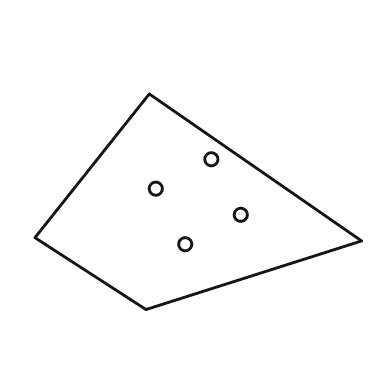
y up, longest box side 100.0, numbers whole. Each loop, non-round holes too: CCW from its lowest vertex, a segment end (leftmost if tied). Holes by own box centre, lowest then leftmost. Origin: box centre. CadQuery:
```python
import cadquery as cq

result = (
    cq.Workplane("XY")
    .moveTo(-16.0, -33.0)
    .lineTo(50.0, -12.0)
    .lineTo(-15.0, 33.0)
    .lineTo(-50.0, -11.0)
    .close()
    .moveTo(-4.0, -13.0)
    .circle(2.0)
    .moveTo(13.0, -4.0)
    .circle(2.0)
    .moveTo(-13.0, 4.0)
    .circle(2.0)
    .moveTo(4.0, 13.0)
    .circle(2.0)
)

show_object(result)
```